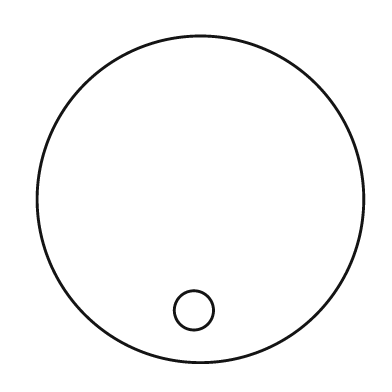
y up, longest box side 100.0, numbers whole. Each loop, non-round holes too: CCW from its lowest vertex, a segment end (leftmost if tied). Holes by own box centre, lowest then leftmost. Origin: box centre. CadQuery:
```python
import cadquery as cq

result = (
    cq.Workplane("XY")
    .moveTo(0.0, 0.0)
    .circle(50.0)
    .moveTo(-2.0, -34.0)
    .circle(6.0)
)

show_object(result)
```